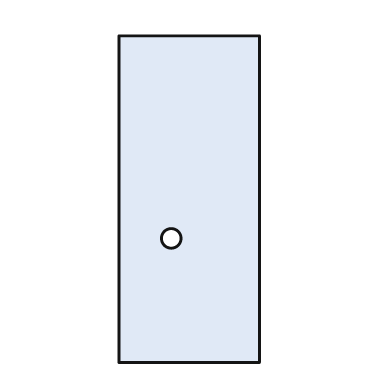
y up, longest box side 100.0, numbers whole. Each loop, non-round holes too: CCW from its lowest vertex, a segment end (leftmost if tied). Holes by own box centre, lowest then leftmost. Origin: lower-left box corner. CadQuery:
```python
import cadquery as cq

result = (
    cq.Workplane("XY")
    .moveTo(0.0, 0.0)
    .lineTo(43.0, 0.0)
    .lineTo(43.0, 100.0)
    .lineTo(0.0, 100.0)
    .close()
    .moveTo(16.0, 38.0)
    .circle(3.0)
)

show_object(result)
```